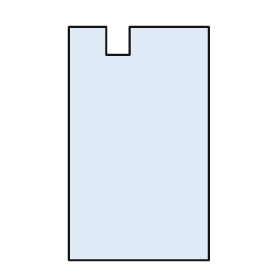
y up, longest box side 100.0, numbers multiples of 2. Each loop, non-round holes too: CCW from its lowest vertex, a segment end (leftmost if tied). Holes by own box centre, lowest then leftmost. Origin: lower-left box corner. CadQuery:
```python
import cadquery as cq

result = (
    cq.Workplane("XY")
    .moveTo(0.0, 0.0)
    .lineTo(60.0, 0.0)
    .lineTo(60.0, 100.0)
    .lineTo(26.0, 100.0)
    .lineTo(26.0, 88.0)
    .lineTo(16.0, 88.0)
    .lineTo(16.0, 100.0)
    .lineTo(0.0, 100.0)
    .close()
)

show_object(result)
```